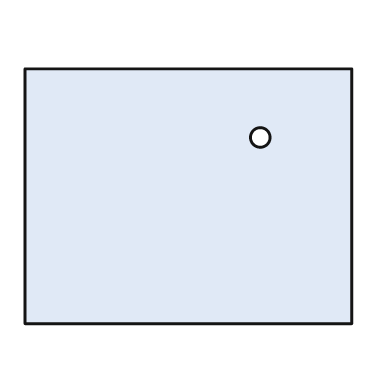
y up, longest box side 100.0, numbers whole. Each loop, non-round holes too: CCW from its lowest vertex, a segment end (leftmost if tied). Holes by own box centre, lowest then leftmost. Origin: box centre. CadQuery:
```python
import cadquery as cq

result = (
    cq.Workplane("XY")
    .moveTo(-50.0, -39.0)
    .lineTo(50.0, -39.0)
    .lineTo(50.0, 39.0)
    .lineTo(-50.0, 39.0)
    .close()
    .moveTo(22.0, 18.0)
    .circle(3.0)
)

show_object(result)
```